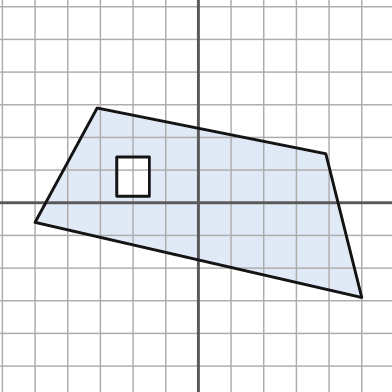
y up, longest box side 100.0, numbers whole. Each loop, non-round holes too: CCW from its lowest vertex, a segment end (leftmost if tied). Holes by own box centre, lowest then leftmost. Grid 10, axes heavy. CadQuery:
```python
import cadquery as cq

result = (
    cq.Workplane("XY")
    .moveTo(50.0, -29.0)
    .lineTo(39.0, 15.0)
    .lineTo(-31.0, 29.0)
    .lineTo(-50.0, -6.0)
    .close()
    .moveTo(-25.0, 2.0)
    .lineTo(-15.0, 2.0)
    .lineTo(-15.0, 14.0)
    .lineTo(-25.0, 14.0)
    .close()
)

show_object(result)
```